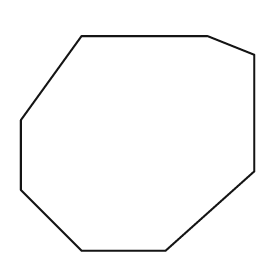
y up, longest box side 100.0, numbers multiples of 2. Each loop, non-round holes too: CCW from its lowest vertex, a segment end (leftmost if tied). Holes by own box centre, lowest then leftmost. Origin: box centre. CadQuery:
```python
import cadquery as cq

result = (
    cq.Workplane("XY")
    .moveTo(-24.0, -46.0)
    .lineTo(12.0, -46.0)
    .lineTo(50.0, -12.0)
    .lineTo(50.0, 38.0)
    .lineTo(30.0, 46.0)
    .lineTo(-24.0, 46.0)
    .lineTo(-50.0, 10.0)
    .lineTo(-50.0, -20.0)
    .close()
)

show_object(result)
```